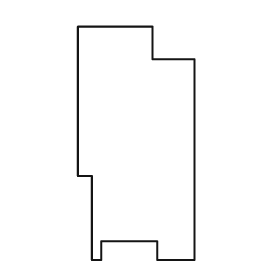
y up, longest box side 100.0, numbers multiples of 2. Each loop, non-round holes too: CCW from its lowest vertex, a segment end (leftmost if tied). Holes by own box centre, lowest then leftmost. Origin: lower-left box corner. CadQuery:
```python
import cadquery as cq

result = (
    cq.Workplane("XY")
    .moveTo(6.0, 0.0)
    .lineTo(10.0, 0.0)
    .lineTo(10.0, 8.0)
    .lineTo(34.0, 8.0)
    .lineTo(34.0, 0.0)
    .lineTo(50.0, 0.0)
    .lineTo(50.0, 86.0)
    .lineTo(32.0, 86.0)
    .lineTo(32.0, 100.0)
    .lineTo(0.0, 100.0)
    .lineTo(0.0, 36.0)
    .lineTo(6.0, 36.0)
    .close()
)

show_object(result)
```